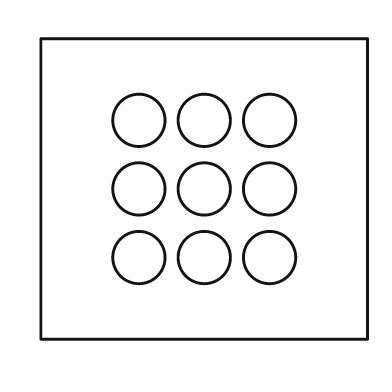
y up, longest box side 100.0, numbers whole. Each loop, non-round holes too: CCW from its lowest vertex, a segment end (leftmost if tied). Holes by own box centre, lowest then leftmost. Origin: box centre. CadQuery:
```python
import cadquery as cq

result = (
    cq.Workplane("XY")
    .moveTo(-50.0, -46.0)
    .lineTo(50.0, -46.0)
    .lineTo(50.0, 46.0)
    .lineTo(-50.0, 46.0)
    .close()
    .moveTo(-20.0, -21.0)
    .circle(8.0)
    .moveTo(0.0, -21.0)
    .circle(8.0)
    .moveTo(20.0, -21.0)
    .circle(8.0)
    .moveTo(-20.0, 0.0)
    .circle(8.0)
    .moveTo(0.0, 0.0)
    .circle(8.0)
    .moveTo(20.0, 0.0)
    .circle(8.0)
    .moveTo(-20.0, 21.0)
    .circle(8.0)
    .moveTo(0.0, 21.0)
    .circle(8.0)
    .moveTo(20.0, 21.0)
    .circle(8.0)
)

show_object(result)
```